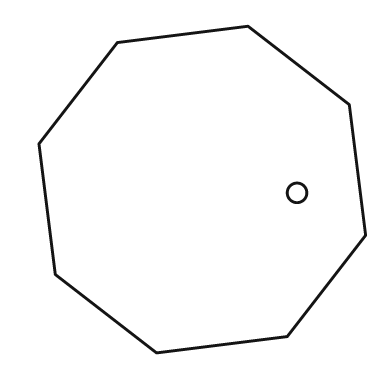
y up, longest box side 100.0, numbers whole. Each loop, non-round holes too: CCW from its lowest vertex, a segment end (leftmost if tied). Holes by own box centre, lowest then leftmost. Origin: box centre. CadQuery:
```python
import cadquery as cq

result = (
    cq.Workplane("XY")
    .moveTo(-14.0, -50.0)
    .lineTo(26.0, -45.0)
    .lineTo(50.0, -14.0)
    .lineTo(45.0, 26.0)
    .lineTo(14.0, 50.0)
    .lineTo(-26.0, 45.0)
    .lineTo(-50.0, 14.0)
    .lineTo(-45.0, -26.0)
    .close()
    .moveTo(29.0, -1.0)
    .circle(3.0)
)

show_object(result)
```